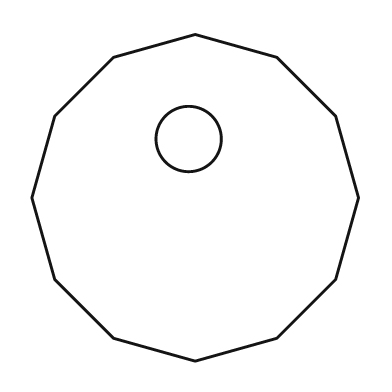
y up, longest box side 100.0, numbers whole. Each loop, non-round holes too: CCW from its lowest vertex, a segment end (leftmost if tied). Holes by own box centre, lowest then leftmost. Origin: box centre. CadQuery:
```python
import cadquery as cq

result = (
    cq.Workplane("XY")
    .moveTo(0.0, -50.0)
    .lineTo(25.0, -43.0)
    .lineTo(43.0, -25.0)
    .lineTo(50.0, 0.0)
    .lineTo(43.0, 25.0)
    .lineTo(25.0, 43.0)
    .lineTo(0.0, 50.0)
    .lineTo(-25.0, 43.0)
    .lineTo(-43.0, 25.0)
    .lineTo(-50.0, 0.0)
    .lineTo(-43.0, -25.0)
    .lineTo(-25.0, -43.0)
    .close()
    .moveTo(-2.0, 18.0)
    .circle(10.0)
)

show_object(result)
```